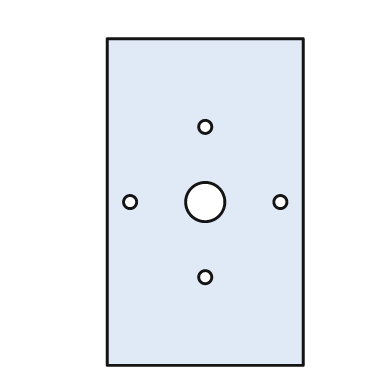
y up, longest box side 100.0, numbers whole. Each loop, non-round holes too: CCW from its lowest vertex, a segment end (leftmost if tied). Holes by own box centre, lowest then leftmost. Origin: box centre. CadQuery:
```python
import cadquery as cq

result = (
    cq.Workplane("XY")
    .moveTo(-30.0, -50.0)
    .lineTo(30.0, -50.0)
    .lineTo(30.0, 50.0)
    .lineTo(-30.0, 50.0)
    .close()
    .moveTo(0.0, -23.0)
    .circle(2.0)
    .moveTo(-23.0, 0.0)
    .circle(2.0)
    .moveTo(0.0, 0.0)
    .circle(6.0)
    .moveTo(23.0, 0.0)
    .circle(2.0)
    .moveTo(0.0, 23.0)
    .circle(2.0)
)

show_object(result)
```